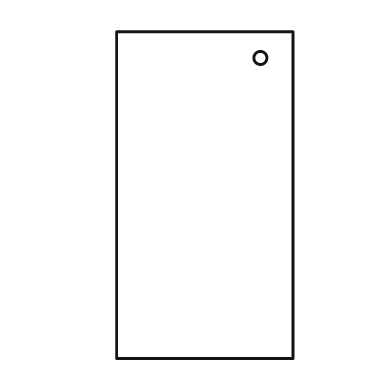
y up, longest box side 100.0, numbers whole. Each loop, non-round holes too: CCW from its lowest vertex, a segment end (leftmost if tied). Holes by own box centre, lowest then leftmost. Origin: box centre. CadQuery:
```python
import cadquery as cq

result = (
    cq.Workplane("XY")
    .moveTo(-27.0, -50.0)
    .lineTo(27.0, -50.0)
    .lineTo(27.0, 50.0)
    .lineTo(-27.0, 50.0)
    .close()
    .moveTo(17.0, 42.0)
    .circle(2.0)
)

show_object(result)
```